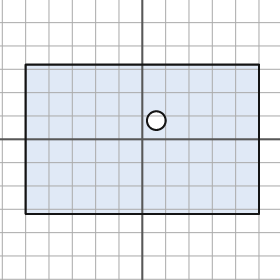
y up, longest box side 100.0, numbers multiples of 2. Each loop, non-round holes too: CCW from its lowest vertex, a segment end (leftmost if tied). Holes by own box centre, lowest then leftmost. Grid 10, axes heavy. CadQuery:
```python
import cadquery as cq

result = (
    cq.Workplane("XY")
    .moveTo(-50.0, -32.0)
    .lineTo(50.0, -32.0)
    .lineTo(50.0, 32.0)
    .lineTo(-50.0, 32.0)
    .close()
    .moveTo(6.0, 8.0)
    .circle(4.0)
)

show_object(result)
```